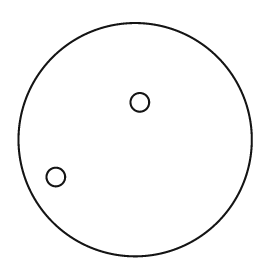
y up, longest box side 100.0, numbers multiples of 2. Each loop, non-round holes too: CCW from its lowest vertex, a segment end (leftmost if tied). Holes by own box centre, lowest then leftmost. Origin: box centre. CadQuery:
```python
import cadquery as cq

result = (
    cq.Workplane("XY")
    .moveTo(0.0, 0.0)
    .circle(50.0)
    .moveTo(-34.0, -16.0)
    .circle(4.0)
    .moveTo(2.0, 16.0)
    .circle(4.0)
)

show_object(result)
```